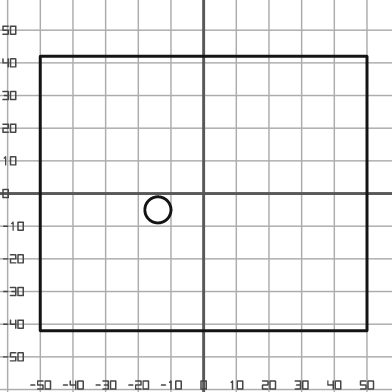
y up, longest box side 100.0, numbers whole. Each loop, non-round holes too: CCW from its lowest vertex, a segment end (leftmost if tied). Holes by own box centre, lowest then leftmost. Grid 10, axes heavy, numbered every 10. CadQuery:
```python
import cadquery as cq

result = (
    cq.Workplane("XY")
    .moveTo(-50.0, -42.0)
    .lineTo(50.0, -42.0)
    .lineTo(50.0, 42.0)
    .lineTo(-50.0, 42.0)
    .close()
    .moveTo(-14.0, -5.0)
    .circle(4.0)
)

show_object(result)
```